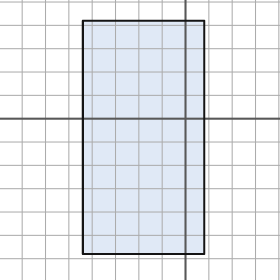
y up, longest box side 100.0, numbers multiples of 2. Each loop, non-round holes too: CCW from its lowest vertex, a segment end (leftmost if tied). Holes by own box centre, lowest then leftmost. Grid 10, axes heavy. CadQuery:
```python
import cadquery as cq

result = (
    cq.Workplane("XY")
    .moveTo(-44.0, -58.0)
    .lineTo(8.0, -58.0)
    .lineTo(8.0, 42.0)
    .lineTo(-44.0, 42.0)
    .close()
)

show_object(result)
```